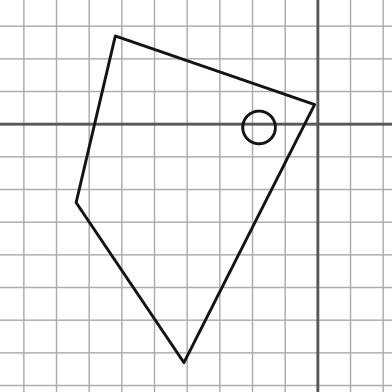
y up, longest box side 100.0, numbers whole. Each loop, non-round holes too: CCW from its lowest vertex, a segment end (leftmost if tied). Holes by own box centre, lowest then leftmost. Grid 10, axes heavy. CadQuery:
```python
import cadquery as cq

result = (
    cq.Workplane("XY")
    .moveTo(-41.0, -73.0)
    .lineTo(-1.0, 6.0)
    .lineTo(-62.0, 27.0)
    .lineTo(-74.0, -24.0)
    .close()
    .moveTo(-18.0, -1.0)
    .circle(5.0)
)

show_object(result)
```